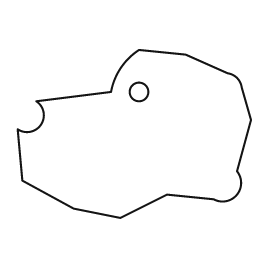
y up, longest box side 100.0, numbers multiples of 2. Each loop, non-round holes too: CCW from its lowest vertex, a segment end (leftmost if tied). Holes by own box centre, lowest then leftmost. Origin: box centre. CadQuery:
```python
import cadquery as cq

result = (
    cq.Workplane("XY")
    .moveTo(-6.0, -36.0)
    .lineTo(14.0, -26.0)
    .lineTo(34.0, -28.0)
    .threePointArc((44.0, -26.0), (44.0, -16.0))
    .lineTo(50.0, 6.0)
    .lineTo(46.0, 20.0)
    .threePointArc((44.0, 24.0), (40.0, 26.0))
    .lineTo(22.0, 34.0)
    .lineTo(2.0, 36.0)
    .threePointArc((-6.0, 28.0), (-10.0, 18.0))
    .lineTo(-42.0, 14.0)
    .threePointArc((-40.0, 4.0), (-50.0, 2.0))
    .lineTo(-48.0, -20.0)
    .lineTo(-26.0, -32.0)
    .close()
    .moveTo(2.0, 18.0)
    .circle(4.0)
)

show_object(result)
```